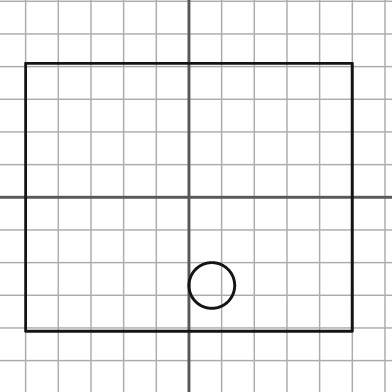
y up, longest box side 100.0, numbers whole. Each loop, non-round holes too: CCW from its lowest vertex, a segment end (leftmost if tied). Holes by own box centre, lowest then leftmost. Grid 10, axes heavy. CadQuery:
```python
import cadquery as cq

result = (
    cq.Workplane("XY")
    .moveTo(-50.0, -41.0)
    .lineTo(50.0, -41.0)
    .lineTo(50.0, 41.0)
    .lineTo(-50.0, 41.0)
    .close()
    .moveTo(7.0, -27.0)
    .circle(7.0)
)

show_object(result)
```